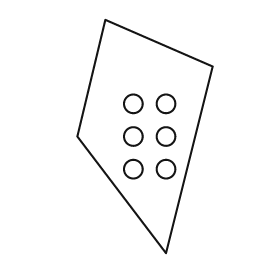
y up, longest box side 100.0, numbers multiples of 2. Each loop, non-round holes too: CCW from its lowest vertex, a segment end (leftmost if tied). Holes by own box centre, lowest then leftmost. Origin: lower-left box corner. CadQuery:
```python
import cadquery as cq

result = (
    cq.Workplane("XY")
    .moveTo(38.0, 0.0)
    .lineTo(58.0, 80.0)
    .lineTo(12.0, 100.0)
    .lineTo(0.0, 50.0)
    .close()
    .moveTo(24.0, 36.0)
    .circle(4.0)
    .moveTo(38.0, 36.0)
    .circle(4.0)
    .moveTo(24.0, 50.0)
    .circle(4.0)
    .moveTo(38.0, 50.0)
    .circle(4.0)
    .moveTo(24.0, 64.0)
    .circle(4.0)
    .moveTo(38.0, 64.0)
    .circle(4.0)
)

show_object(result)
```